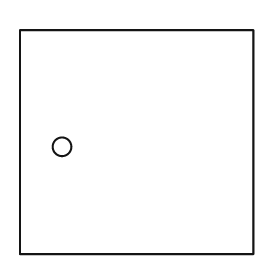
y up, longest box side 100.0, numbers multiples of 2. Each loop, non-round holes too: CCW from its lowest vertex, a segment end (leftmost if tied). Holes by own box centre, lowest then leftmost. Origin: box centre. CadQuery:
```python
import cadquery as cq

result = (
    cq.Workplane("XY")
    .moveTo(-50.0, -48.0)
    .lineTo(50.0, -48.0)
    .lineTo(50.0, 48.0)
    .lineTo(-50.0, 48.0)
    .close()
    .moveTo(-32.0, -2.0)
    .circle(4.0)
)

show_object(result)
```